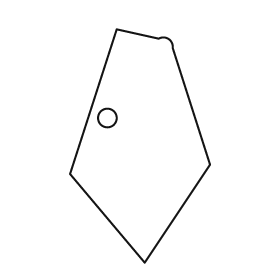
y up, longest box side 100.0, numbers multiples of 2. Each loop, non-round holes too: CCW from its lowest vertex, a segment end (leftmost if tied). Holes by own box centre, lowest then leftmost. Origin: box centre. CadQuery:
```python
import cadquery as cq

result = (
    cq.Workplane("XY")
    .moveTo(2.0, -50.0)
    .lineTo(30.0, -8.0)
    .lineTo(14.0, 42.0)
    .threePointArc((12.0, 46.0), (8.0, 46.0))
    .lineTo(-10.0, 50.0)
    .lineTo(-30.0, -12.0)
    .close()
    .moveTo(-14.0, 12.0)
    .circle(4.0)
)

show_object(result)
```